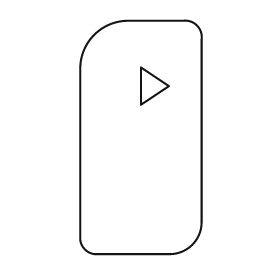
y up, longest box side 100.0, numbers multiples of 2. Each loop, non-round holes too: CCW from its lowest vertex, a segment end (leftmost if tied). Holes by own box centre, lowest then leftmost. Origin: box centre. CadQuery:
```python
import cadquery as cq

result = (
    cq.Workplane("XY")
    .moveTo(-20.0, -50.0)
    .lineTo(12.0, -50.0)
    .threePointArc((22.0, -46.0), (26.0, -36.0))
    .lineTo(26.0, 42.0)
    .threePointArc((24.0, 48.0), (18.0, 50.0))
    .lineTo(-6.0, 50.0)
    .threePointArc((-20.0, 44.0), (-26.0, 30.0))
    .lineTo(-26.0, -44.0)
    .threePointArc((-24.0, -48.0), (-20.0, -50.0))
    .close()
    .moveTo(0.0, 14.0)
    .lineTo(12.0, 22.0)
    .lineTo(0.0, 30.0)
    .close()
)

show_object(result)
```